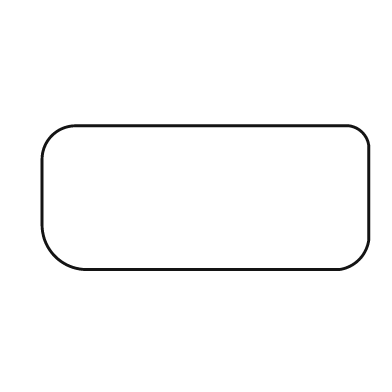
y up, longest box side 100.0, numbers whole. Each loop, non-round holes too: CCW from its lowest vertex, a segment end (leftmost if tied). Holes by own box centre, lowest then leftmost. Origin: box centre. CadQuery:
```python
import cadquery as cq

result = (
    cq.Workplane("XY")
    .moveTo(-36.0, -22.0)
    .lineTo(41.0, -22.0)
    .threePointArc((47.0, -19.0), (50.0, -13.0))
    .lineTo(50.0, 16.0)
    .threePointArc((48.0, 20.0), (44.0, 22.0))
    .lineTo(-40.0, 22.0)
    .threePointArc((-47.0, 19.0), (-50.0, 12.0))
    .lineTo(-50.0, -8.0)
    .threePointArc((-46.0, -18.0), (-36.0, -22.0))
    .close()
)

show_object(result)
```